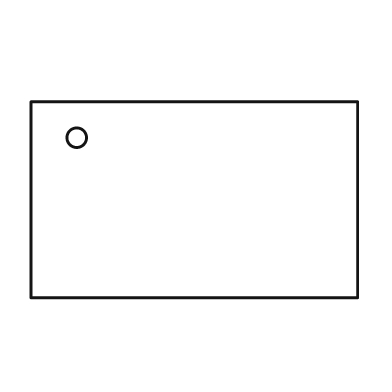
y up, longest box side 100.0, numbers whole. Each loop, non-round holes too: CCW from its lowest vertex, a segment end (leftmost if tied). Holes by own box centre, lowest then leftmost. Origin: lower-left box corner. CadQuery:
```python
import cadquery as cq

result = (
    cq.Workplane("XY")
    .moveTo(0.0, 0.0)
    .lineTo(100.0, 0.0)
    .lineTo(100.0, 60.0)
    .lineTo(0.0, 60.0)
    .close()
    .moveTo(14.0, 49.0)
    .circle(3.0)
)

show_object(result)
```